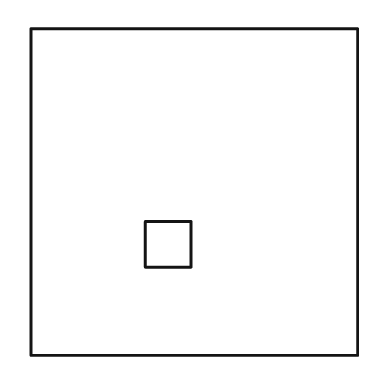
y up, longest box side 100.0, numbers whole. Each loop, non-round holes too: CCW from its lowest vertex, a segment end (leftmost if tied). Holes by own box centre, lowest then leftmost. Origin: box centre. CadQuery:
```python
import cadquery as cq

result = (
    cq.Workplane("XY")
    .moveTo(-50.0, -50.0)
    .lineTo(50.0, -50.0)
    .lineTo(50.0, 50.0)
    .lineTo(-50.0, 50.0)
    .close()
    .moveTo(-15.0, -23.0)
    .lineTo(-1.0, -23.0)
    .lineTo(-1.0, -9.0)
    .lineTo(-15.0, -9.0)
    .close()
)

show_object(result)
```